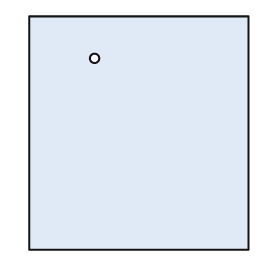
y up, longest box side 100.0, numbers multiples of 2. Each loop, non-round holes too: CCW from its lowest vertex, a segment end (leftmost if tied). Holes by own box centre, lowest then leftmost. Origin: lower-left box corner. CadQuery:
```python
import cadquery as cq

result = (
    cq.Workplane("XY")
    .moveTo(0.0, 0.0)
    .lineTo(94.0, 0.0)
    .lineTo(94.0, 100.0)
    .lineTo(0.0, 100.0)
    .close()
    .moveTo(28.0, 82.0)
    .circle(2.0)
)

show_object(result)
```